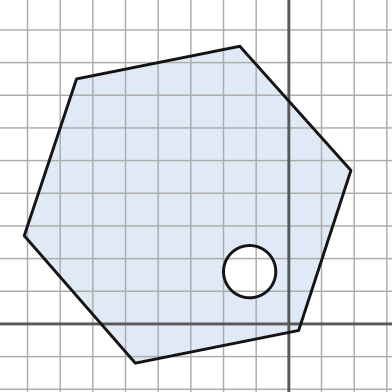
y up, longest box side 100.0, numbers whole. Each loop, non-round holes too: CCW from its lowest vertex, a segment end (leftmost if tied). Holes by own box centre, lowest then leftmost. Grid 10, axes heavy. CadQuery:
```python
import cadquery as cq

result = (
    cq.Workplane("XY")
    .moveTo(-47.0, -12.0)
    .lineTo(3.0, -2.0)
    .lineTo(19.0, 47.0)
    .lineTo(-15.0, 85.0)
    .lineTo(-65.0, 75.0)
    .lineTo(-81.0, 27.0)
    .close()
    .moveTo(-12.0, 16.0)
    .circle(8.0)
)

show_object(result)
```